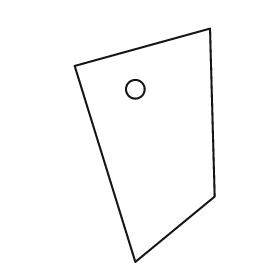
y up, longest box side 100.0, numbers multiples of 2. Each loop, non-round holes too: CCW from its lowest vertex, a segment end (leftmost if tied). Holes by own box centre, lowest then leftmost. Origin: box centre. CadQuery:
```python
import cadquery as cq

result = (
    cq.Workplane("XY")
    .moveTo(-4.0, -50.0)
    .lineTo(30.0, -22.0)
    .lineTo(28.0, 50.0)
    .lineTo(-30.0, 34.0)
    .close()
    .moveTo(-4.0, 24.0)
    .circle(4.0)
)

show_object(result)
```